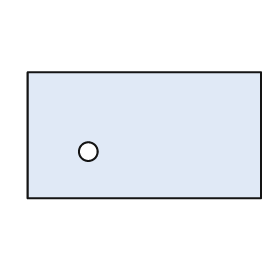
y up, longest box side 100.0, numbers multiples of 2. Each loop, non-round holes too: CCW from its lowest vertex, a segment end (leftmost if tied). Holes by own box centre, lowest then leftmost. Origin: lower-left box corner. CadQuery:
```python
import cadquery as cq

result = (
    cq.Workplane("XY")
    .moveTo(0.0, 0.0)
    .lineTo(100.0, 0.0)
    .lineTo(100.0, 54.0)
    .lineTo(0.0, 54.0)
    .close()
    .moveTo(26.0, 20.0)
    .circle(4.0)
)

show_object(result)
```